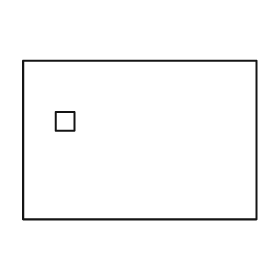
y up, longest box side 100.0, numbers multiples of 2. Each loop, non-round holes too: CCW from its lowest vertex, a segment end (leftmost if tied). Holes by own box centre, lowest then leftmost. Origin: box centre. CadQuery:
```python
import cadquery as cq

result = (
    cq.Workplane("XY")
    .moveTo(-50.0, -34.0)
    .lineTo(50.0, -34.0)
    .lineTo(50.0, 34.0)
    .lineTo(-50.0, 34.0)
    .close()
    .moveTo(-36.0, 4.0)
    .lineTo(-28.0, 4.0)
    .lineTo(-28.0, 12.0)
    .lineTo(-36.0, 12.0)
    .close()
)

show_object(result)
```